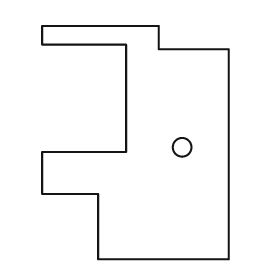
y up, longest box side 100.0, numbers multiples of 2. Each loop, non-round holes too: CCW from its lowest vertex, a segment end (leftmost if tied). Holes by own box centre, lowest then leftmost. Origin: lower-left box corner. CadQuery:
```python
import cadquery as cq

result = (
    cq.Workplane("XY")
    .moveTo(24.0, 0.0)
    .lineTo(80.0, 0.0)
    .lineTo(80.0, 90.0)
    .lineTo(50.0, 90.0)
    .lineTo(50.0, 100.0)
    .lineTo(0.0, 100.0)
    .lineTo(0.0, 92.0)
    .lineTo(36.0, 92.0)
    .lineTo(36.0, 46.0)
    .lineTo(0.0, 46.0)
    .lineTo(0.0, 28.0)
    .lineTo(24.0, 28.0)
    .close()
    .moveTo(60.0, 48.0)
    .circle(4.0)
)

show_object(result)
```